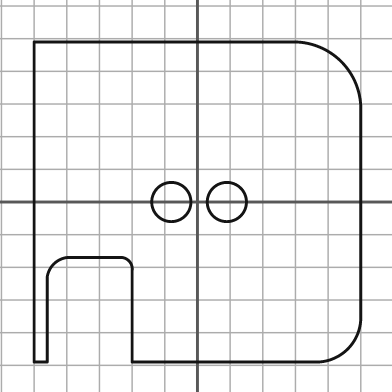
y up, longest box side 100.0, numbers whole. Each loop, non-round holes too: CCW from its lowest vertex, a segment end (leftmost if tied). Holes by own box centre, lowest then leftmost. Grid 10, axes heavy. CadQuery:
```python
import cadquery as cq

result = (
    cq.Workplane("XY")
    .moveTo(-50.0, -49.0)
    .lineTo(-46.0, -49.0)
    .lineTo(-46.0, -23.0)
    .threePointArc((-44.0, -19.0), (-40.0, -17.0))
    .lineTo(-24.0, -17.0)
    .threePointArc((-21.0, -18.0), (-20.0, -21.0))
    .lineTo(-20.0, -49.0)
    .lineTo(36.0, -49.0)
    .threePointArc((46.0, -45.0), (50.0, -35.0))
    .lineTo(50.0, 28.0)
    .threePointArc((44.0, 43.0), (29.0, 49.0))
    .lineTo(-50.0, 49.0)
    .close()
    .moveTo(-8.0, 0.0)
    .circle(6.0)
    .moveTo(9.0, 0.0)
    .circle(6.0)
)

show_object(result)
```